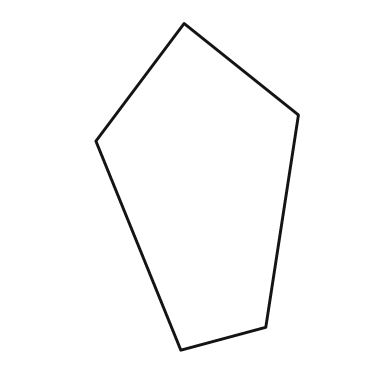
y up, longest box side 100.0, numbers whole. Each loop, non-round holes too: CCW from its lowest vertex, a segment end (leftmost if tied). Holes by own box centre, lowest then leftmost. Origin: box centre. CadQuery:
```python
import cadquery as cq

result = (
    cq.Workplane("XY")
    .moveTo(-5.0, -50.0)
    .lineTo(21.0, -43.0)
    .lineTo(31.0, 22.0)
    .lineTo(-4.0, 50.0)
    .lineTo(-31.0, 14.0)
    .close()
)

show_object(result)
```